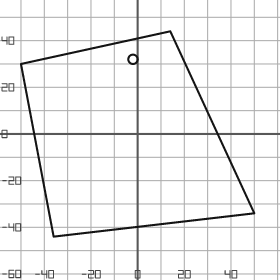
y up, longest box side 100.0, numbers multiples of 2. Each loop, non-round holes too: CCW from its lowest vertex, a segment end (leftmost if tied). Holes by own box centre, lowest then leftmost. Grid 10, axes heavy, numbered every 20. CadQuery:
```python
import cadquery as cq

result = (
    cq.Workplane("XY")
    .moveTo(-36.0, -44.0)
    .lineTo(50.0, -34.0)
    .lineTo(14.0, 44.0)
    .lineTo(-50.0, 30.0)
    .close()
    .moveTo(-2.0, 32.0)
    .circle(2.0)
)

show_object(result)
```